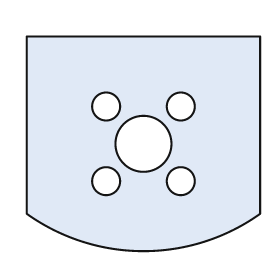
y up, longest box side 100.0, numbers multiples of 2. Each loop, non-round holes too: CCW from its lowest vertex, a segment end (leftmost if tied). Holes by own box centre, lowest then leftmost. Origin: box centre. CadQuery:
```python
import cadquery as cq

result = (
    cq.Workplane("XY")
    .moveTo(-50.0, -30.0)
    .threePointArc((0.0, -46.0), (50.0, -30.0))
    .lineTo(50.0, 46.0)
    .lineTo(-50.0, 46.0)
    .close()
    .moveTo(-16.0, -16.0)
    .circle(6.0)
    .moveTo(16.0, -16.0)
    .circle(6.0)
    .moveTo(0.0, 0.0)
    .circle(12.0)
    .moveTo(-16.0, 16.0)
    .circle(6.0)
    .moveTo(16.0, 16.0)
    .circle(6.0)
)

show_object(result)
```